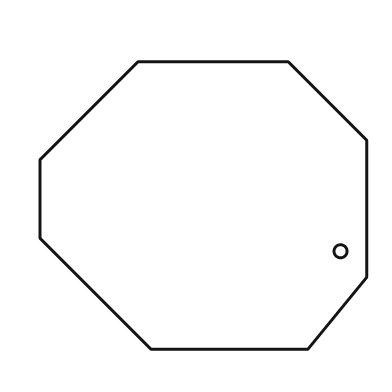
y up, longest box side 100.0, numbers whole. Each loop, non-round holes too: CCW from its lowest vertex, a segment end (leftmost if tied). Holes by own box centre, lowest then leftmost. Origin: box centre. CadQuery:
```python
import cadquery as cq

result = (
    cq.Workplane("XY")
    .moveTo(-16.0, -44.0)
    .lineTo(32.0, -44.0)
    .lineTo(50.0, -22.0)
    .lineTo(50.0, 20.0)
    .lineTo(26.0, 44.0)
    .lineTo(-20.0, 44.0)
    .lineTo(-50.0, 14.0)
    .lineTo(-50.0, -10.0)
    .close()
    .moveTo(42.0, -14.0)
    .circle(2.0)
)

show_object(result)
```